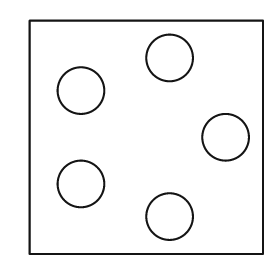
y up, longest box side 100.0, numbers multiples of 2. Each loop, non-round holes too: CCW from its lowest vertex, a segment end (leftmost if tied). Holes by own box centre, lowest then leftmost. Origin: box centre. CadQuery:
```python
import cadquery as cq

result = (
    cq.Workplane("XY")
    .moveTo(-50.0, -50.0)
    .lineTo(50.0, -50.0)
    .lineTo(50.0, 50.0)
    .lineTo(-50.0, 50.0)
    .close()
    .moveTo(10.0, -34.0)
    .circle(10.0)
    .moveTo(-28.0, -20.0)
    .circle(10.0)
    .moveTo(34.0, 0.0)
    .circle(10.0)
    .moveTo(-28.0, 20.0)
    .circle(10.0)
    .moveTo(10.0, 34.0)
    .circle(10.0)
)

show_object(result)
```